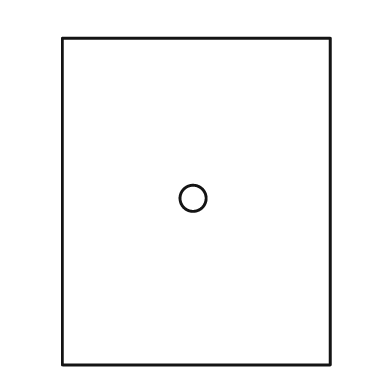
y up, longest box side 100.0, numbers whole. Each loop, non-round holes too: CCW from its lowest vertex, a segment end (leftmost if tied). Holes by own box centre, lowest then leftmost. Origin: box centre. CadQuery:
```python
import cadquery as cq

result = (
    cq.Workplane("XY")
    .moveTo(-41.0, -50.0)
    .lineTo(41.0, -50.0)
    .lineTo(41.0, 50.0)
    .lineTo(-41.0, 50.0)
    .close()
    .moveTo(-1.0, 1.0)
    .circle(4.0)
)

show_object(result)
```